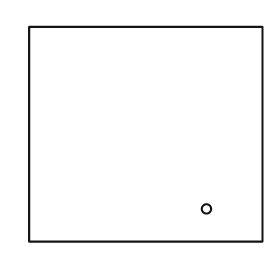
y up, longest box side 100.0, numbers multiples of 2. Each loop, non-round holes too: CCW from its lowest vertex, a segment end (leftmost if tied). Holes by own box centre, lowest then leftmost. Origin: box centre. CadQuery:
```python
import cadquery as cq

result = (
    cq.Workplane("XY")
    .moveTo(-50.0, -46.0)
    .lineTo(50.0, -46.0)
    .lineTo(50.0, 46.0)
    .lineTo(-50.0, 46.0)
    .close()
    .moveTo(26.0, -32.0)
    .circle(2.0)
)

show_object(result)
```